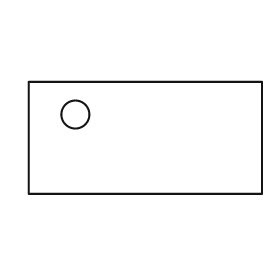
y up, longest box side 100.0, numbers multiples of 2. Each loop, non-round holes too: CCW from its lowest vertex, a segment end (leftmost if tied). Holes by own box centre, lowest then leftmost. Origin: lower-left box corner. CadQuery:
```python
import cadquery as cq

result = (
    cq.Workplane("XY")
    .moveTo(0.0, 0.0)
    .lineTo(100.0, 0.0)
    .lineTo(100.0, 48.0)
    .lineTo(0.0, 48.0)
    .close()
    .moveTo(20.0, 34.0)
    .circle(6.0)
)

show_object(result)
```